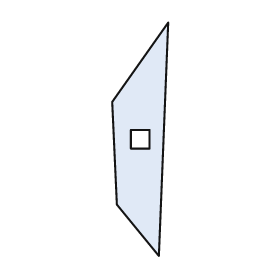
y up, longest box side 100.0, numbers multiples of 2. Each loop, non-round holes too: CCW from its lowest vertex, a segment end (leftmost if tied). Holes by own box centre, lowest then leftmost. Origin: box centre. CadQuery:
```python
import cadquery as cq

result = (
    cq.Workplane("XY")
    .moveTo(8.0, -50.0)
    .lineTo(12.0, 50.0)
    .lineTo(-12.0, 16.0)
    .lineTo(-10.0, -28.0)
    .close()
    .moveTo(-4.0, -4.0)
    .lineTo(4.0, -4.0)
    .lineTo(4.0, 4.0)
    .lineTo(-4.0, 4.0)
    .close()
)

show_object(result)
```